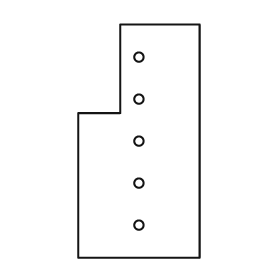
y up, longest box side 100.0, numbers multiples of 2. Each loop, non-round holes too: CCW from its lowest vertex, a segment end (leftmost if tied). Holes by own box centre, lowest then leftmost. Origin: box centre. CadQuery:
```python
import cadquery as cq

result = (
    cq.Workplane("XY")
    .moveTo(-26.0, -50.0)
    .lineTo(26.0, -50.0)
    .lineTo(26.0, 50.0)
    .lineTo(-8.0, 50.0)
    .lineTo(-8.0, 12.0)
    .lineTo(-26.0, 12.0)
    .close()
    .moveTo(0.0, -36.0)
    .circle(2.0)
    .moveTo(0.0, -18.0)
    .circle(2.0)
    .moveTo(0.0, 0.0)
    .circle(2.0)
    .moveTo(0.0, 18.0)
    .circle(2.0)
    .moveTo(0.0, 36.0)
    .circle(2.0)
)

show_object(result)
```